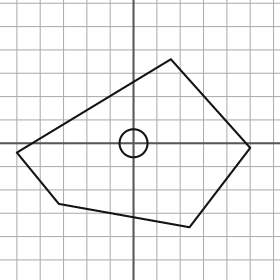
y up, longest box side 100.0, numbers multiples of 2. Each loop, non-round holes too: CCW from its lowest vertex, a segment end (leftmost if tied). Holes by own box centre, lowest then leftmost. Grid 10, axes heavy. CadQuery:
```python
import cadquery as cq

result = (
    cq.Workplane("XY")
    .moveTo(24.0, -36.0)
    .lineTo(50.0, -2.0)
    .lineTo(16.0, 36.0)
    .lineTo(-50.0, -4.0)
    .lineTo(-32.0, -26.0)
    .close()
    .moveTo(0.0, 0.0)
    .circle(6.0)
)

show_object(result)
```